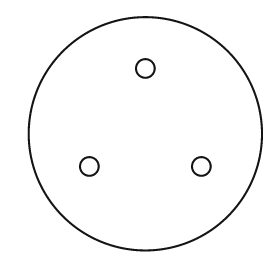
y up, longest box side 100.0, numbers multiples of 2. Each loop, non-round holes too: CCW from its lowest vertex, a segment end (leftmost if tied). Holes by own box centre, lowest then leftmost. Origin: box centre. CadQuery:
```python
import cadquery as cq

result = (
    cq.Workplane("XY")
    .moveTo(0.0, 0.0)
    .circle(50.0)
    .moveTo(-24.0, -14.0)
    .circle(4.0)
    .moveTo(24.0, -14.0)
    .circle(4.0)
    .moveTo(0.0, 28.0)
    .circle(4.0)
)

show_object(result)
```